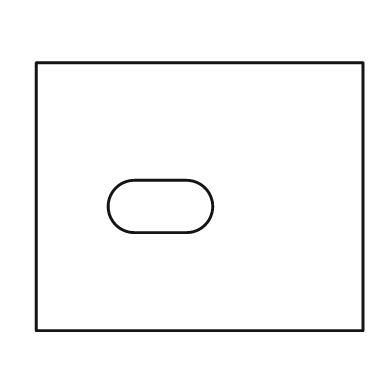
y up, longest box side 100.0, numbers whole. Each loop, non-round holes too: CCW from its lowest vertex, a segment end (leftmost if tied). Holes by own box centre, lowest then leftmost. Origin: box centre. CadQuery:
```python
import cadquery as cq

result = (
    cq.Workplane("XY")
    .moveTo(-50.0, -41.0)
    .lineTo(50.0, -41.0)
    .lineTo(50.0, 41.0)
    .lineTo(-50.0, 41.0)
    .close()
    .moveTo(-20.0, -11.0)
    .lineTo(-4.0, -11.0)
    .threePointArc((4.0, -3.0), (-4.0, 5.0))
    .lineTo(-20.0, 5.0)
    .threePointArc((-28.0, -3.0), (-20.0, -11.0))
    .close()
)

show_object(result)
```